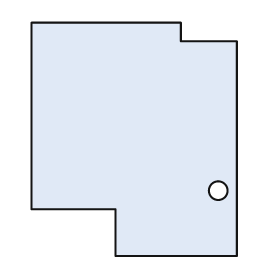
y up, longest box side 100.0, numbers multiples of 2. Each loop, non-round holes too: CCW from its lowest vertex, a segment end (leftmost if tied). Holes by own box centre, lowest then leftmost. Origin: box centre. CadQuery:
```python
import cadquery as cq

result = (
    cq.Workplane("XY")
    .moveTo(-8.0, -50.0)
    .lineTo(44.0, -50.0)
    .lineTo(44.0, 42.0)
    .lineTo(20.0, 42.0)
    .lineTo(20.0, 50.0)
    .lineTo(-44.0, 50.0)
    .lineTo(-44.0, -30.0)
    .lineTo(-8.0, -30.0)
    .close()
    .moveTo(36.0, -22.0)
    .circle(4.0)
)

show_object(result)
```